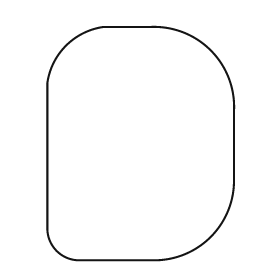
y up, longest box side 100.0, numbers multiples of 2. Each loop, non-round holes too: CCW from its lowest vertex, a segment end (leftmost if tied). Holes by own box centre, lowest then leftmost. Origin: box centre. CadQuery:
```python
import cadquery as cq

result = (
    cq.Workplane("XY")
    .moveTo(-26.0, -50.0)
    .lineTo(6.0, -50.0)
    .threePointArc((30.0, -40.0), (40.0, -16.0))
    .lineTo(40.0, 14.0)
    .threePointArc((30.0, 40.0), (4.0, 50.0))
    .lineTo(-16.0, 50.0)
    .threePointArc((-32.0, 42.0), (-40.0, 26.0))
    .lineTo(-40.0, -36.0)
    .threePointArc((-36.0, -46.0), (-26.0, -50.0))
    .close()
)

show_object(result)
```